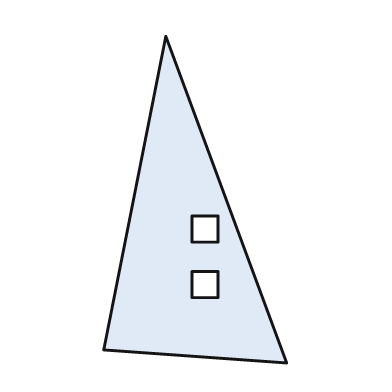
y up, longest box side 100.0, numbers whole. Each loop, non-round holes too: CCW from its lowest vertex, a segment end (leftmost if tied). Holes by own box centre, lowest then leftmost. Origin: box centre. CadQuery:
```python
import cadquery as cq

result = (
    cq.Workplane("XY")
    .moveTo(28.0, -50.0)
    .lineTo(-9.0, 50.0)
    .lineTo(-28.0, -46.0)
    .close()
    .moveTo(-1.0, -30.0)
    .lineTo(7.0, -30.0)
    .lineTo(7.0, -22.0)
    .lineTo(-1.0, -22.0)
    .close()
    .moveTo(-1.0, -13.0)
    .lineTo(7.0, -13.0)
    .lineTo(7.0, -5.0)
    .lineTo(-1.0, -5.0)
    .close()
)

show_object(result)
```